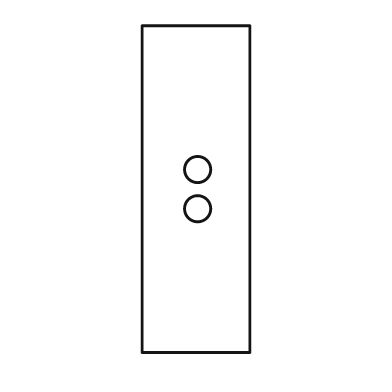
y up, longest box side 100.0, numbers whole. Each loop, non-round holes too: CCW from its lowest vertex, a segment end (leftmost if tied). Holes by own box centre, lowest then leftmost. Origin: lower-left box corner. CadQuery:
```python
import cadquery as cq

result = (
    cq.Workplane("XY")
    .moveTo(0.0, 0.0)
    .lineTo(33.0, 0.0)
    .lineTo(33.0, 100.0)
    .lineTo(0.0, 100.0)
    .close()
    .moveTo(17.0, 44.0)
    .circle(4.0)
    .moveTo(17.0, 56.0)
    .circle(4.0)
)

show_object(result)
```